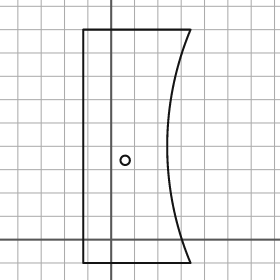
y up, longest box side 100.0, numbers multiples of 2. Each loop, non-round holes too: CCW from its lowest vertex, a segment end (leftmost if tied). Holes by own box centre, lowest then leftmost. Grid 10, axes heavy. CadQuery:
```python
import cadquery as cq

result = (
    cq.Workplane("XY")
    .moveTo(-12.0, -10.0)
    .lineTo(34.0, -10.0)
    .threePointArc((24.0, 40.0), (34.0, 90.0))
    .lineTo(-12.0, 90.0)
    .close()
    .moveTo(6.0, 34.0)
    .circle(2.0)
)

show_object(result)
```